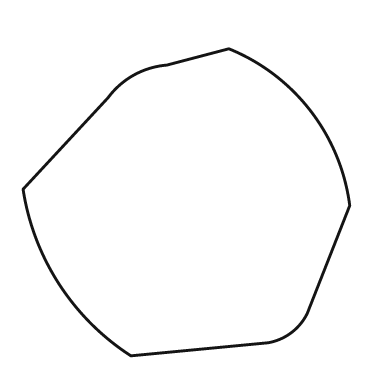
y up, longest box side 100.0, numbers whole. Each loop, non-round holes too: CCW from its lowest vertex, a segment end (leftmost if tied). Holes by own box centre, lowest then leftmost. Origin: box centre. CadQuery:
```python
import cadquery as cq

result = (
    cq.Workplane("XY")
    .moveTo(-17.0, -47.0)
    .lineTo(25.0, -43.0)
    .threePointArc((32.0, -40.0), (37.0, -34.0))
    .lineTo(50.0, -1.0)
    .threePointArc((38.0, 28.0), (13.0, 47.0))
    .lineTo(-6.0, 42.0)
    .threePointArc((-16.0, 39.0), (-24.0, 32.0))
    .lineTo(-50.0, 4.0)
    .threePointArc((-39.0, -25.0), (-17.0, -47.0))
    .close()
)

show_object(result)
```